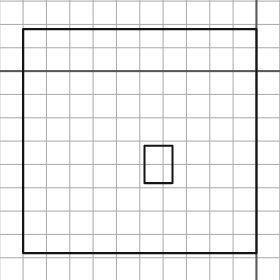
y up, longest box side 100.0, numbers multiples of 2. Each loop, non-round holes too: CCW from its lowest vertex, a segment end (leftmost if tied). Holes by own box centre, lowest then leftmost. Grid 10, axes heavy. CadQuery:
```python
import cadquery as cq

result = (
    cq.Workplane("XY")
    .moveTo(-100.0, -78.0)
    .lineTo(0.0, -78.0)
    .lineTo(0.0, 18.0)
    .lineTo(-100.0, 18.0)
    .close()
    .moveTo(-48.0, -48.0)
    .lineTo(-36.0, -48.0)
    .lineTo(-36.0, -32.0)
    .lineTo(-48.0, -32.0)
    .close()
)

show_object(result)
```